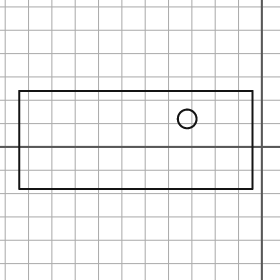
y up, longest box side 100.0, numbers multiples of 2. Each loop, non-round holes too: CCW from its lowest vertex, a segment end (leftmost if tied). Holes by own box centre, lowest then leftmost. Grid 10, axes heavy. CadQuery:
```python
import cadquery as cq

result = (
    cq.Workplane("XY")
    .moveTo(-104.0, -18.0)
    .lineTo(-4.0, -18.0)
    .lineTo(-4.0, 24.0)
    .lineTo(-104.0, 24.0)
    .close()
    .moveTo(-32.0, 12.0)
    .circle(4.0)
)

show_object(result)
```